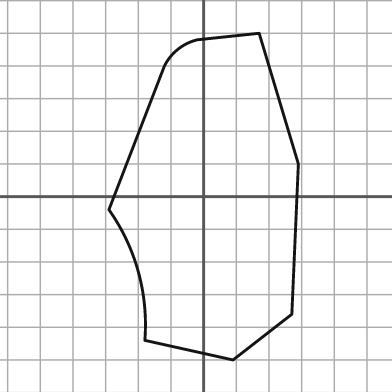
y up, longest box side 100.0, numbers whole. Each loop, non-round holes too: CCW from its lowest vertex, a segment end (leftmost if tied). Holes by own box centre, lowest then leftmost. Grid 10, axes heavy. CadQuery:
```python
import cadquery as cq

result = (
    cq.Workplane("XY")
    .moveTo(9.0, -50.0)
    .lineTo(27.0, -36.0)
    .lineTo(29.0, 10.0)
    .lineTo(17.0, 50.0)
    .lineTo(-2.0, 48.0)
    .threePointArc((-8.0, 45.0), (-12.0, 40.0))
    .lineTo(-29.0, -4.0)
    .threePointArc((-20.0, -23.0), (-18.0, -44.0))
    .close()
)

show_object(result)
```